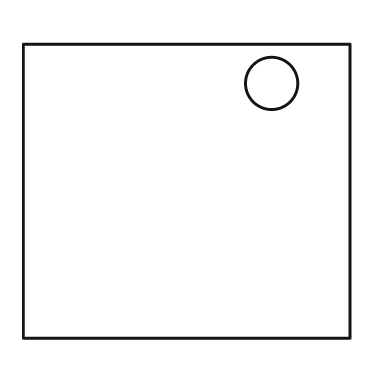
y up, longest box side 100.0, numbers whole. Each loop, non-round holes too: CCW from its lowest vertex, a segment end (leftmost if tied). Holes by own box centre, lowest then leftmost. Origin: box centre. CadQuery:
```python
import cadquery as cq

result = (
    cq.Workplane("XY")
    .moveTo(-50.0, -45.0)
    .lineTo(50.0, -45.0)
    .lineTo(50.0, 45.0)
    .lineTo(-50.0, 45.0)
    .close()
    .moveTo(26.0, 33.0)
    .circle(8.0)
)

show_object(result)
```